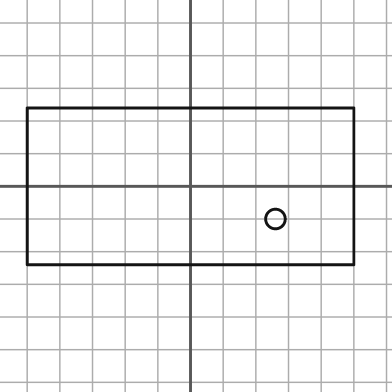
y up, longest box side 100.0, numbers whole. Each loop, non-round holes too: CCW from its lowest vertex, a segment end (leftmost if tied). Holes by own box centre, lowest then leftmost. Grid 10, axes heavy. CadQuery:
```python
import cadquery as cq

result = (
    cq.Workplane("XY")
    .moveTo(-50.0, -24.0)
    .lineTo(50.0, -24.0)
    .lineTo(50.0, 24.0)
    .lineTo(-50.0, 24.0)
    .close()
    .moveTo(26.0, -10.0)
    .circle(3.0)
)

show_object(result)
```